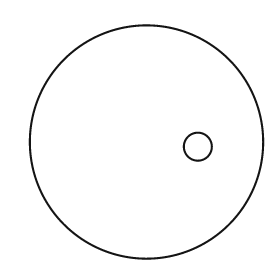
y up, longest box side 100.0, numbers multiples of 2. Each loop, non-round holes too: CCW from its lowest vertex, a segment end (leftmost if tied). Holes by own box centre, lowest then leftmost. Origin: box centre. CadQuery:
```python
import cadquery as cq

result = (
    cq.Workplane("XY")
    .moveTo(0.0, 0.0)
    .circle(50.0)
    .moveTo(22.0, -2.0)
    .circle(6.0)
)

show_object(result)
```